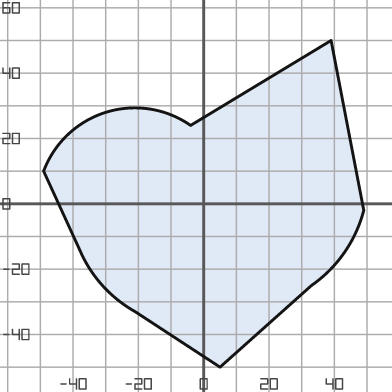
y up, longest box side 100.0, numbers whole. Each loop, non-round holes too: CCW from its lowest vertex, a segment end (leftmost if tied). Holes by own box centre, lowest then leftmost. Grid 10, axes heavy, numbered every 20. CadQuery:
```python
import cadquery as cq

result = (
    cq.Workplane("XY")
    .moveTo(5.0, -50.0)
    .lineTo(33.0, -25.0)
    .threePointArc((43.0, -15.0), (49.0, -2.0))
    .lineTo(39.0, 50.0)
    .lineTo(-4.0, 24.0)
    .threePointArc((-30.0, 28.0), (-49.0, 10.0))
    .lineTo(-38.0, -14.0)
    .threePointArc((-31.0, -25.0), (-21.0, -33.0))
    .close()
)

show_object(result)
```